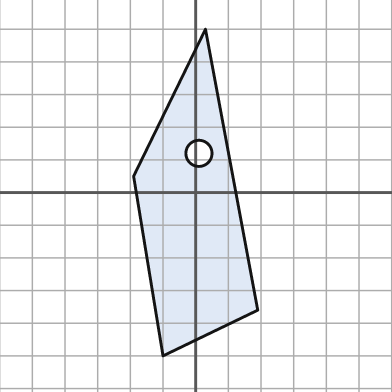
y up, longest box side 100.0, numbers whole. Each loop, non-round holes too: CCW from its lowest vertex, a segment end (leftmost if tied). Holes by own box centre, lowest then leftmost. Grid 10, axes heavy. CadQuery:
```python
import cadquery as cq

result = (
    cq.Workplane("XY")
    .moveTo(-10.0, -50.0)
    .lineTo(19.0, -36.0)
    .lineTo(3.0, 50.0)
    .lineTo(-19.0, 5.0)
    .close()
    .moveTo(1.0, 12.0)
    .circle(4.0)
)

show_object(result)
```